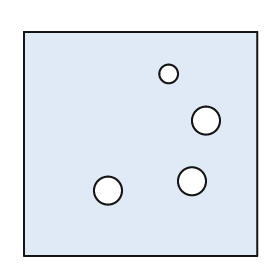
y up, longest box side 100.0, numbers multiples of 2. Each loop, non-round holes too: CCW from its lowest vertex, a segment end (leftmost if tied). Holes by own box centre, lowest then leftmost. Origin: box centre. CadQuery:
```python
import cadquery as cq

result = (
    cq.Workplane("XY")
    .moveTo(-50.0, -48.0)
    .lineTo(50.0, -48.0)
    .lineTo(50.0, 48.0)
    .lineTo(-50.0, 48.0)
    .close()
    .moveTo(-14.0, -20.0)
    .circle(6.0)
    .moveTo(22.0, -16.0)
    .circle(6.0)
    .moveTo(28.0, 10.0)
    .circle(6.0)
    .moveTo(12.0, 30.0)
    .circle(4.0)
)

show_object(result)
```